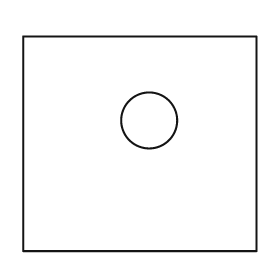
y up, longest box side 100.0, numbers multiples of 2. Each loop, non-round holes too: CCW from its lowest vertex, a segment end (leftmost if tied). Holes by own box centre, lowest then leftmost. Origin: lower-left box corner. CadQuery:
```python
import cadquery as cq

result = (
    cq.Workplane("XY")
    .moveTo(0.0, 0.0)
    .lineTo(100.0, 0.0)
    .lineTo(100.0, 92.0)
    .lineTo(0.0, 92.0)
    .close()
    .moveTo(54.0, 56.0)
    .circle(12.0)
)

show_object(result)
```